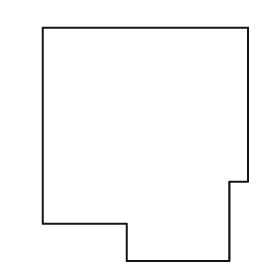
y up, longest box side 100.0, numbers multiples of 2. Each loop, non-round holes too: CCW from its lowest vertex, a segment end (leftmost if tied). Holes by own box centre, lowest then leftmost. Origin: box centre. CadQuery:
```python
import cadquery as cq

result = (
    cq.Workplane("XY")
    .moveTo(-8.0, -50.0)
    .lineTo(36.0, -50.0)
    .lineTo(36.0, -16.0)
    .lineTo(44.0, -16.0)
    .lineTo(44.0, 50.0)
    .lineTo(-44.0, 50.0)
    .lineTo(-44.0, -34.0)
    .lineTo(-8.0, -34.0)
    .close()
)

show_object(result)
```